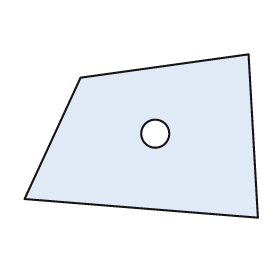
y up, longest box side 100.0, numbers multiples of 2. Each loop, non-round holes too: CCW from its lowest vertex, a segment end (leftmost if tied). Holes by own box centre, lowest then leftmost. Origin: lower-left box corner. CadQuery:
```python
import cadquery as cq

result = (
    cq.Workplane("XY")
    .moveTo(100.0, 0.0)
    .lineTo(96.0, 70.0)
    .lineTo(24.0, 60.0)
    .lineTo(0.0, 8.0)
    .close()
    .moveTo(56.0, 36.0)
    .circle(6.0)
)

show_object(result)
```